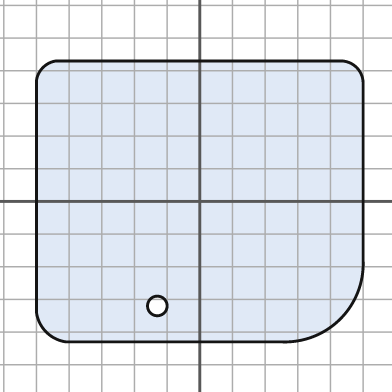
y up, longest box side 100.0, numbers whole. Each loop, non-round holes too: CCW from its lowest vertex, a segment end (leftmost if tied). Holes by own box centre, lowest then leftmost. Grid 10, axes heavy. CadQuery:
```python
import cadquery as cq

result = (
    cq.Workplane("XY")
    .moveTo(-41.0, -43.0)
    .lineTo(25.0, -43.0)
    .threePointArc((43.0, -36.0), (50.0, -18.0))
    .lineTo(50.0, 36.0)
    .threePointArc((48.0, 41.0), (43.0, 43.0))
    .lineTo(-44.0, 43.0)
    .threePointArc((-48.0, 41.0), (-50.0, 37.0))
    .lineTo(-50.0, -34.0)
    .threePointArc((-47.0, -40.0), (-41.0, -43.0))
    .close()
    .moveTo(-13.0, -32.0)
    .circle(3.0)
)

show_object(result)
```